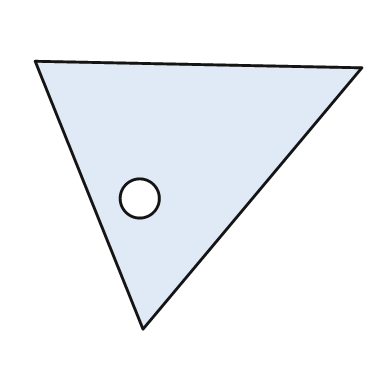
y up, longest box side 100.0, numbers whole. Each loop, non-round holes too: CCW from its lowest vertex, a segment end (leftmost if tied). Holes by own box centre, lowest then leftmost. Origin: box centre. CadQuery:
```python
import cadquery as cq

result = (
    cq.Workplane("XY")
    .moveTo(-17.0, -41.0)
    .lineTo(50.0, 39.0)
    .lineTo(-50.0, 41.0)
    .close()
    .moveTo(-18.0, -1.0)
    .circle(6.0)
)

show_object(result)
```